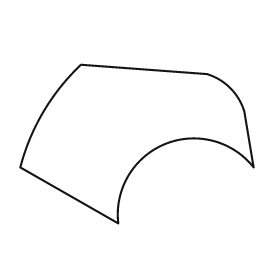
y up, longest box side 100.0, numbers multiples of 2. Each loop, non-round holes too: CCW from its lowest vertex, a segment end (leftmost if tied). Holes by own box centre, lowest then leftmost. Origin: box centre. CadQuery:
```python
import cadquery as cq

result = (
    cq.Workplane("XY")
    .moveTo(-8.0, -34.0)
    .threePointArc((12.0, 0.0), (50.0, -10.0))
    .lineTo(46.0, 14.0)
    .threePointArc((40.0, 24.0), (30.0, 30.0))
    .lineTo(-24.0, 34.0)
    .threePointArc((-40.0, 14.0), (-50.0, -10.0))
    .close()
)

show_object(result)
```